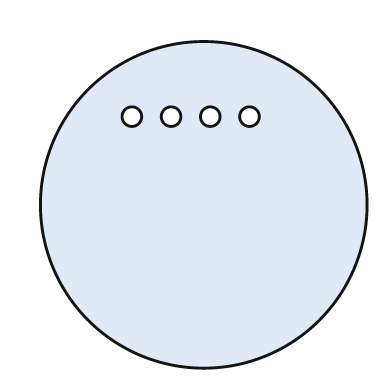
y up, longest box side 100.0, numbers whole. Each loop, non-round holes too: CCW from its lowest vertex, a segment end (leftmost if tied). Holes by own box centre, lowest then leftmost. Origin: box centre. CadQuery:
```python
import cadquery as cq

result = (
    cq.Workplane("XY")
    .moveTo(0.0, 0.0)
    .circle(50.0)
    .moveTo(-22.0, 27.0)
    .circle(3.0)
    .moveTo(-10.0, 27.0)
    .circle(3.0)
    .moveTo(2.0, 27.0)
    .circle(3.0)
    .moveTo(14.0, 27.0)
    .circle(3.0)
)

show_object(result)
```